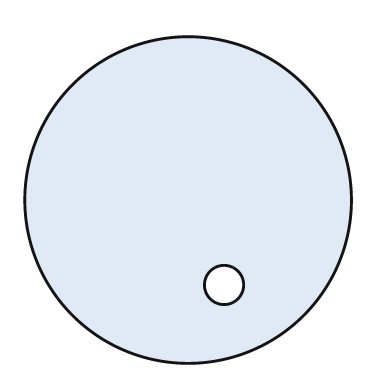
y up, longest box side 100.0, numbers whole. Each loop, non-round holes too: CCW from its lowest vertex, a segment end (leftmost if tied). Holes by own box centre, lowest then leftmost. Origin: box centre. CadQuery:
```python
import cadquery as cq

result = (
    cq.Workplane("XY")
    .moveTo(0.0, 0.0)
    .circle(50.0)
    .moveTo(11.0, -26.0)
    .circle(6.0)
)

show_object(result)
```